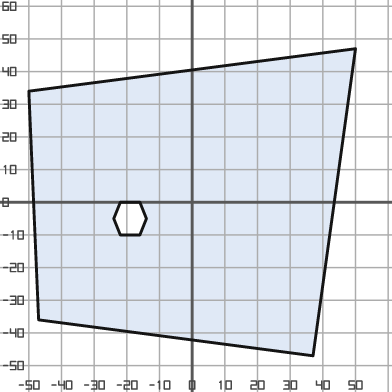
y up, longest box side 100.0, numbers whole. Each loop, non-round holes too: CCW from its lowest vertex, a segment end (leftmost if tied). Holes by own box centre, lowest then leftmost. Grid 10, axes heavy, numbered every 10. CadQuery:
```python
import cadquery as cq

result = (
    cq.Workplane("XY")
    .moveTo(37.0, -47.0)
    .lineTo(50.0, 47.0)
    .lineTo(-50.0, 34.0)
    .lineTo(-47.0, -36.0)
    .close()
    .moveTo(-22.0, -10.0)
    .lineTo(-16.0, -10.0)
    .lineTo(-14.0, -5.0)
    .lineTo(-16.0, 0.0)
    .lineTo(-22.0, 0.0)
    .lineTo(-24.0, -5.0)
    .close()
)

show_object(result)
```